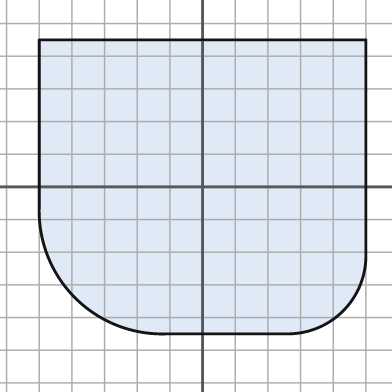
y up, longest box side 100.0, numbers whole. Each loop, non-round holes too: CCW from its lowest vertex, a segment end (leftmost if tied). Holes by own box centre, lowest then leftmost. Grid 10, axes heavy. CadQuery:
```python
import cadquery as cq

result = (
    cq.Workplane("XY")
    .moveTo(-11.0, -45.0)
    .lineTo(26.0, -45.0)
    .threePointArc((43.0, -38.0), (50.0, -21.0))
    .lineTo(50.0, 45.0)
    .lineTo(-50.0, 45.0)
    .lineTo(-50.0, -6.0)
    .threePointArc((-39.0, -34.0), (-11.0, -45.0))
    .close()
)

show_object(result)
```